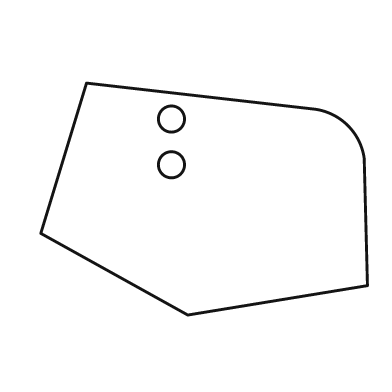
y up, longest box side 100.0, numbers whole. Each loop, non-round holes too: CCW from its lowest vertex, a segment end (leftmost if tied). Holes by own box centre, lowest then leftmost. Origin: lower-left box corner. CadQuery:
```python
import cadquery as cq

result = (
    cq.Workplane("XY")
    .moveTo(45.0, 0.0)
    .lineTo(100.0, 9.0)
    .lineTo(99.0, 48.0)
    .threePointArc((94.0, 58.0), (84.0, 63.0))
    .lineTo(14.0, 71.0)
    .lineTo(0.0, 25.0)
    .close()
    .moveTo(40.0, 46.0)
    .circle(4.0)
    .moveTo(40.0, 60.0)
    .circle(4.0)
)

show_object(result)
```